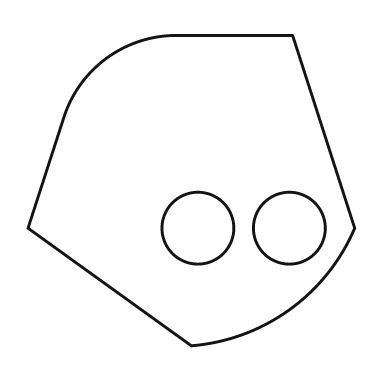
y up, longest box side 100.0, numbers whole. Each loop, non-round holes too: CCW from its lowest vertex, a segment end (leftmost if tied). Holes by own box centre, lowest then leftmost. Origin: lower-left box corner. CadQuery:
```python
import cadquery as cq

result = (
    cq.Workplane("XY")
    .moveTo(50.0, 0.0)
    .threePointArc((80.0, 11.0), (100.0, 36.0))
    .lineTo(81.0, 95.0)
    .lineTo(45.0, 95.0)
    .threePointArc((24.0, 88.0), (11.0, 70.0))
    .lineTo(0.0, 36.0)
    .close()
    .moveTo(52.0, 36.0)
    .circle(11.0)
    .moveTo(80.0, 36.0)
    .circle(11.0)
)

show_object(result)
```